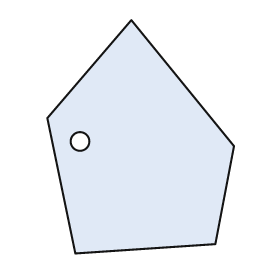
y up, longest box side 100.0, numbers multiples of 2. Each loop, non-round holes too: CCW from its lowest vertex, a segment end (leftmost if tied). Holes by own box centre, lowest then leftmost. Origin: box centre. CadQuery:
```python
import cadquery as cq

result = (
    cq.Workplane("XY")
    .moveTo(-28.0, -50.0)
    .lineTo(32.0, -46.0)
    .lineTo(40.0, -4.0)
    .lineTo(-4.0, 50.0)
    .lineTo(-40.0, 8.0)
    .close()
    .moveTo(-26.0, -2.0)
    .circle(4.0)
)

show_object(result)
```